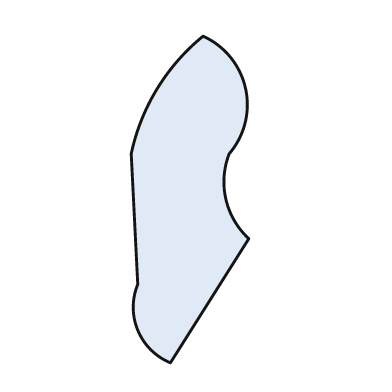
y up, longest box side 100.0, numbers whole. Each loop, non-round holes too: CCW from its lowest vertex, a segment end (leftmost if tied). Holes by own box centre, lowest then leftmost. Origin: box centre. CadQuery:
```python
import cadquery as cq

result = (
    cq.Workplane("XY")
    .moveTo(-6.0, -50.0)
    .lineTo(18.0, -12.0)
    .threePointArc((11.0, 0.0), (12.0, 14.0))
    .threePointArc((17.0, 34.0), (4.0, 50.0))
    .threePointArc((-10.0, 34.0), (-18.0, 14.0))
    .lineTo(-16.0, -26.0)
    .threePointArc((-16.0, -40.0), (-6.0, -50.0))
    .close()
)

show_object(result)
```